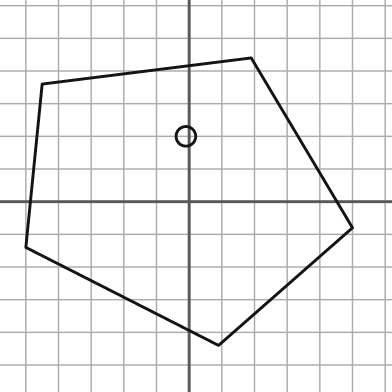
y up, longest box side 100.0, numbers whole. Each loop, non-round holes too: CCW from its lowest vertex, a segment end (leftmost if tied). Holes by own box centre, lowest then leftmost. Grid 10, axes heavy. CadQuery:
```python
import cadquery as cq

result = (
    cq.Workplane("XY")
    .moveTo(9.0, -44.0)
    .lineTo(50.0, -8.0)
    .lineTo(19.0, 44.0)
    .lineTo(-45.0, 36.0)
    .lineTo(-50.0, -14.0)
    .close()
    .moveTo(-1.0, 20.0)
    .circle(3.0)
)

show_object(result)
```